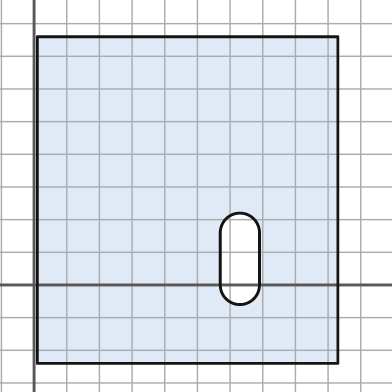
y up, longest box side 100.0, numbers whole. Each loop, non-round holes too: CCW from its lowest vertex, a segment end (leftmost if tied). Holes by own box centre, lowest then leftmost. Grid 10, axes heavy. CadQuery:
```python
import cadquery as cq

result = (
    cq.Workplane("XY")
    .moveTo(1.0, -24.0)
    .lineTo(93.0, -24.0)
    .lineTo(93.0, 76.0)
    .lineTo(1.0, 76.0)
    .close()
    .moveTo(57.0, 0.0)
    .threePointArc((63.0, -6.0), (69.0, 0.0))
    .lineTo(69.0, 16.0)
    .threePointArc((63.0, 22.0), (57.0, 16.0))
    .close()
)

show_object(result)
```